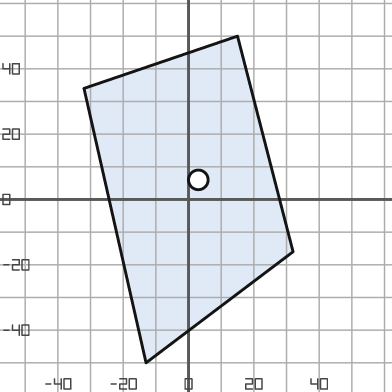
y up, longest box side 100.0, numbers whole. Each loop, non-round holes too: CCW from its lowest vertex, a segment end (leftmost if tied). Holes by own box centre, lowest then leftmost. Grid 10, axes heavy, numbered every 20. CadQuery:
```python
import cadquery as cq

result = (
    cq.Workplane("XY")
    .moveTo(-13.0, -50.0)
    .lineTo(32.0, -16.0)
    .lineTo(15.0, 50.0)
    .lineTo(-32.0, 34.0)
    .close()
    .moveTo(3.0, 6.0)
    .circle(3.0)
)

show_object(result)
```